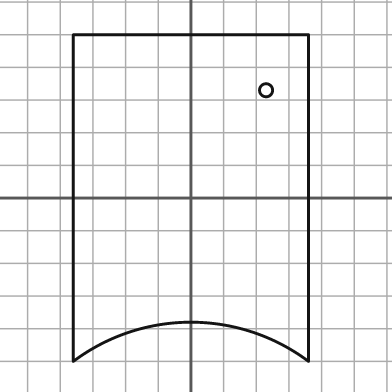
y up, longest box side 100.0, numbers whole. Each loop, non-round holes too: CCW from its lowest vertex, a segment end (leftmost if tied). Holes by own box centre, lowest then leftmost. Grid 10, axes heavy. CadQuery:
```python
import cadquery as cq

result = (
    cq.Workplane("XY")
    .moveTo(-36.0, -50.0)
    .threePointArc((0.0, -38.0), (36.0, -50.0))
    .lineTo(36.0, 50.0)
    .lineTo(-36.0, 50.0)
    .close()
    .moveTo(23.0, 33.0)
    .circle(2.0)
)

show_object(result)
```